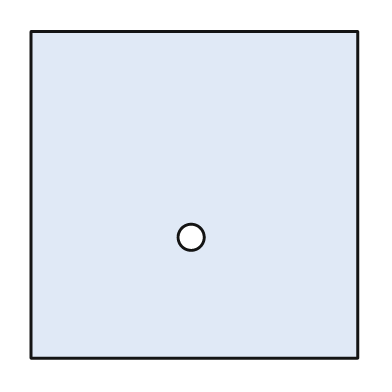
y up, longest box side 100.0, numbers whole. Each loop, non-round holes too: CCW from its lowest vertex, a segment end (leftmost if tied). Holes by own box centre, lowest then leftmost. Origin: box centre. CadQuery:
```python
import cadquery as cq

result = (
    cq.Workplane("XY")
    .moveTo(-50.0, -50.0)
    .lineTo(50.0, -50.0)
    .lineTo(50.0, 50.0)
    .lineTo(-50.0, 50.0)
    .close()
    .moveTo(-1.0, -13.0)
    .circle(4.0)
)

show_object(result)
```